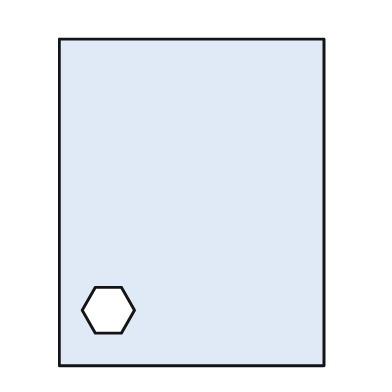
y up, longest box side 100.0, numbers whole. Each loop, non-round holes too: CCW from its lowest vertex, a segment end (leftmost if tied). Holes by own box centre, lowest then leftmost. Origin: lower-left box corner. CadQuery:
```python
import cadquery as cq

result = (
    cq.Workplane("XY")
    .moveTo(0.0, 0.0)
    .lineTo(81.0, 0.0)
    .lineTo(81.0, 100.0)
    .lineTo(0.0, 100.0)
    .close()
    .moveTo(11.0, 10.0)
    .lineTo(19.0, 10.0)
    .lineTo(23.0, 17.0)
    .lineTo(19.0, 24.0)
    .lineTo(11.0, 24.0)
    .lineTo(7.0, 17.0)
    .close()
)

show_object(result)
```